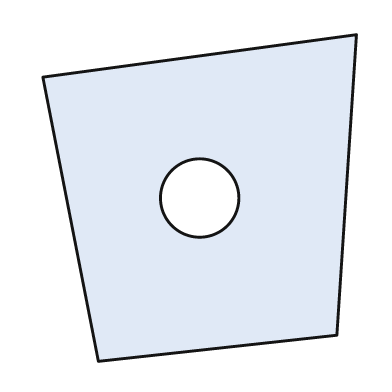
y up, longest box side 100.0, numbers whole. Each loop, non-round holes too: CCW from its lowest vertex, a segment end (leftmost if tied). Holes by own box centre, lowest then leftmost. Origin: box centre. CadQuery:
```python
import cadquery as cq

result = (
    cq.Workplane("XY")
    .moveTo(-31.0, -50.0)
    .lineTo(42.0, -42.0)
    .lineTo(48.0, 50.0)
    .lineTo(-48.0, 37.0)
    .close()
    .moveTo(0.0, 0.0)
    .circle(12.0)
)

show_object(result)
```